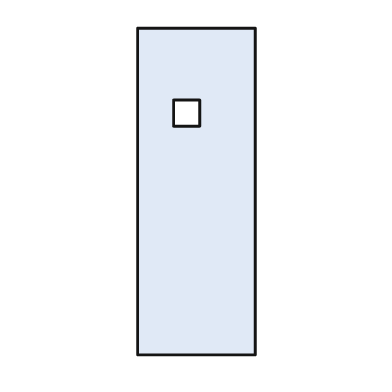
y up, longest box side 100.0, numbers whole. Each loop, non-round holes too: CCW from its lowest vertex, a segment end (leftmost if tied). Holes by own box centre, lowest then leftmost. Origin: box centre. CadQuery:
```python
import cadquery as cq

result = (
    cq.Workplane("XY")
    .moveTo(-18.0, -50.0)
    .lineTo(18.0, -50.0)
    .lineTo(18.0, 50.0)
    .lineTo(-18.0, 50.0)
    .close()
    .moveTo(-7.0, 20.0)
    .lineTo(1.0, 20.0)
    .lineTo(1.0, 28.0)
    .lineTo(-7.0, 28.0)
    .close()
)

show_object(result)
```